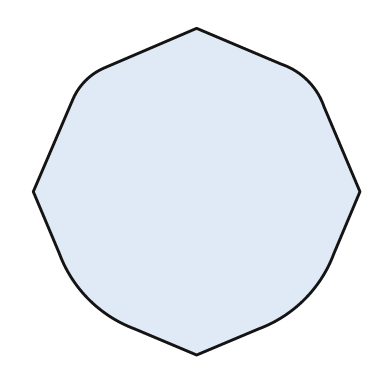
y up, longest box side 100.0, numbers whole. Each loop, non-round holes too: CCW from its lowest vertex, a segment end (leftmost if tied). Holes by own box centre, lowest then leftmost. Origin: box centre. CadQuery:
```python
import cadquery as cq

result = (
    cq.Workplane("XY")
    .moveTo(0.0, -50.0)
    .lineTo(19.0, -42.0)
    .threePointArc((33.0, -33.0), (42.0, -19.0))
    .lineTo(50.0, 0.0)
    .lineTo(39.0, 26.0)
    .threePointArc((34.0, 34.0), (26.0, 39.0))
    .lineTo(0.0, 50.0)
    .lineTo(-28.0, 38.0)
    .threePointArc((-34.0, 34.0), (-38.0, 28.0))
    .lineTo(-50.0, 0.0)
    .lineTo(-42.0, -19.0)
    .threePointArc((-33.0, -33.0), (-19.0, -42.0))
    .close()
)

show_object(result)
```